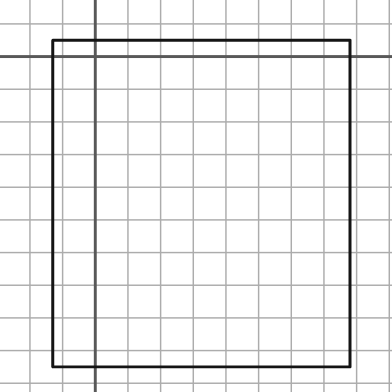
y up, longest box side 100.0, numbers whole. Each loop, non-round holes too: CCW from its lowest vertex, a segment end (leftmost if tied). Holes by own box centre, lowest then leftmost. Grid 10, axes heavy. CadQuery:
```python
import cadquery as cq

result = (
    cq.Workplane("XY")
    .moveTo(-13.0, -95.0)
    .lineTo(78.0, -95.0)
    .lineTo(78.0, 5.0)
    .lineTo(-13.0, 5.0)
    .close()
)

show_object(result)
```